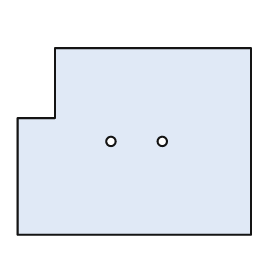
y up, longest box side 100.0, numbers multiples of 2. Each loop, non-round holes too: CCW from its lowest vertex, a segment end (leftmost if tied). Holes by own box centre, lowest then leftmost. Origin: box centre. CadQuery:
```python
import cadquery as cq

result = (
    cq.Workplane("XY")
    .moveTo(-50.0, -40.0)
    .lineTo(50.0, -40.0)
    .lineTo(50.0, 40.0)
    .lineTo(-34.0, 40.0)
    .lineTo(-34.0, 10.0)
    .lineTo(-50.0, 10.0)
    .close()
    .moveTo(-10.0, 0.0)
    .circle(2.0)
    .moveTo(12.0, 0.0)
    .circle(2.0)
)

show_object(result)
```